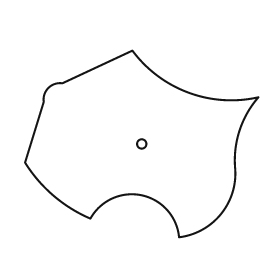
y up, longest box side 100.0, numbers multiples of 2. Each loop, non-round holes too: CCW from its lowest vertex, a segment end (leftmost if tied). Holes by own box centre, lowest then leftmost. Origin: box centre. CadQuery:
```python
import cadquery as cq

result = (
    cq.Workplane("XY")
    .moveTo(16.0, -40.0)
    .threePointArc((34.0, -30.0), (40.0, -10.0))
    .threePointArc((42.0, 6.0), (50.0, 20.0))
    .threePointArc((20.0, 22.0), (-4.0, 40.0))
    .lineTo(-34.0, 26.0)
    .threePointArc((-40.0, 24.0), (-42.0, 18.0))
    .lineTo(-50.0, -8.0)
    .threePointArc((-38.0, -22.0), (-22.0, -32.0))
    .threePointArc((0.0, -22.0), (16.0, -40.0))
    .close()
    .moveTo(0.0, 0.0)
    .circle(2.0)
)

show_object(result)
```